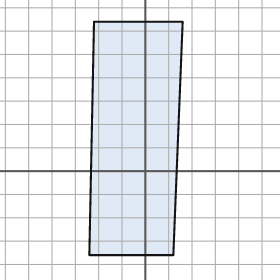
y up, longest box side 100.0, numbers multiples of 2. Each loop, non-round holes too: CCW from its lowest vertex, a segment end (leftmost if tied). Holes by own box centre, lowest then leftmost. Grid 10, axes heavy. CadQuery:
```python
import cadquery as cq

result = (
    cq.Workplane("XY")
    .moveTo(-24.0, -36.0)
    .lineTo(12.0, -36.0)
    .lineTo(16.0, 64.0)
    .lineTo(-22.0, 64.0)
    .close()
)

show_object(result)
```